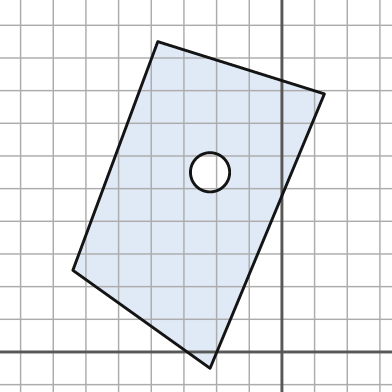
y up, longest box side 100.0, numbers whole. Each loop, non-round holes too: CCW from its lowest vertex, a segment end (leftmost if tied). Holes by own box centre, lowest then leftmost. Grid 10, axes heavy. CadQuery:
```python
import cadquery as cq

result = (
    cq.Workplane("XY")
    .moveTo(-22.0, -5.0)
    .lineTo(13.0, 79.0)
    .lineTo(-38.0, 95.0)
    .lineTo(-64.0, 25.0)
    .close()
    .moveTo(-22.0, 55.0)
    .circle(6.0)
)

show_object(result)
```